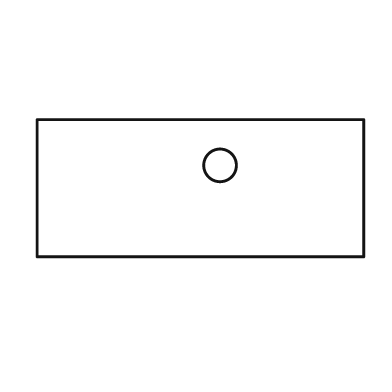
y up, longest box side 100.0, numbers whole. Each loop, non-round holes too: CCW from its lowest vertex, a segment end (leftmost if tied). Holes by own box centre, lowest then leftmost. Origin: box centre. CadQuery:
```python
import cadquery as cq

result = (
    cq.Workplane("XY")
    .moveTo(-50.0, -21.0)
    .lineTo(50.0, -21.0)
    .lineTo(50.0, 21.0)
    .lineTo(-50.0, 21.0)
    .close()
    .moveTo(6.0, 7.0)
    .circle(5.0)
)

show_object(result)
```